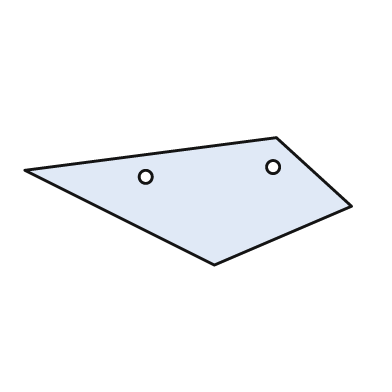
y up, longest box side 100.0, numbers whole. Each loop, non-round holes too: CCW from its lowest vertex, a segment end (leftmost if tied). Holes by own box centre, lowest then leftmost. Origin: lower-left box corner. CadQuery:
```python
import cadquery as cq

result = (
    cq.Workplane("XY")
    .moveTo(58.0, 0.0)
    .lineTo(100.0, 18.0)
    .lineTo(77.0, 39.0)
    .lineTo(0.0, 29.0)
    .close()
    .moveTo(37.0, 27.0)
    .circle(2.0)
    .moveTo(76.0, 30.0)
    .circle(2.0)
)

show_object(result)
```